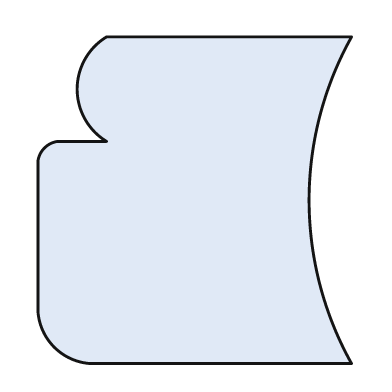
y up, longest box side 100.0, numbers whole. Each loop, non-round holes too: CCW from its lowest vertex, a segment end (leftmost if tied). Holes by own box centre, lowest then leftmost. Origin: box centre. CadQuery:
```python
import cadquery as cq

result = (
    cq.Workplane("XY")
    .moveTo(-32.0, -50.0)
    .lineTo(48.0, -50.0)
    .threePointArc((35.0, 0.0), (48.0, 50.0))
    .lineTo(-27.0, 50.0)
    .threePointArc((-36.0, 34.0), (-27.0, 18.0))
    .lineTo(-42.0, 18.0)
    .threePointArc((-46.0, 16.0), (-48.0, 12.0))
    .lineTo(-48.0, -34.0)
    .threePointArc((-43.0, -45.0), (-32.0, -50.0))
    .close()
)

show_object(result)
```